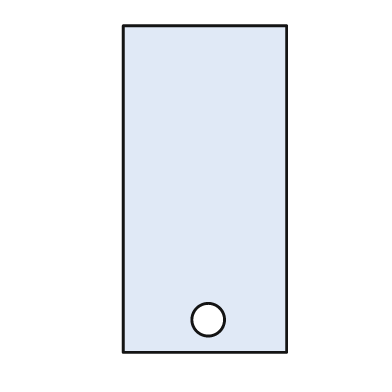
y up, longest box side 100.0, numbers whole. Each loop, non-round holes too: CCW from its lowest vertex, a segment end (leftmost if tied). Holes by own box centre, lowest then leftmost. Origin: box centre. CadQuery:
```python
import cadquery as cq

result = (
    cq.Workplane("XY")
    .moveTo(-25.0, -50.0)
    .lineTo(25.0, -50.0)
    .lineTo(25.0, 50.0)
    .lineTo(-25.0, 50.0)
    .close()
    .moveTo(1.0, -40.0)
    .circle(5.0)
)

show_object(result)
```